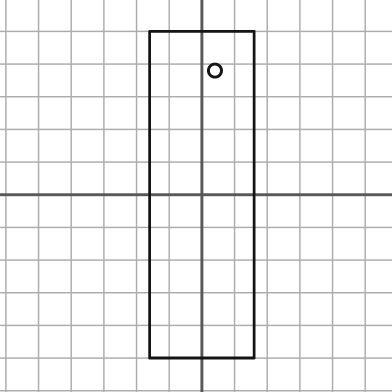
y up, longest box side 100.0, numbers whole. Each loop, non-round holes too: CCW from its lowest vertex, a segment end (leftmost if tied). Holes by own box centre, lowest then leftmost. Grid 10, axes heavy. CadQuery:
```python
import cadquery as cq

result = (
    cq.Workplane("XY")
    .moveTo(-16.0, -50.0)
    .lineTo(16.0, -50.0)
    .lineTo(16.0, 50.0)
    .lineTo(-16.0, 50.0)
    .close()
    .moveTo(4.0, 38.0)
    .circle(2.0)
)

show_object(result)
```